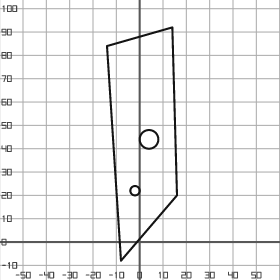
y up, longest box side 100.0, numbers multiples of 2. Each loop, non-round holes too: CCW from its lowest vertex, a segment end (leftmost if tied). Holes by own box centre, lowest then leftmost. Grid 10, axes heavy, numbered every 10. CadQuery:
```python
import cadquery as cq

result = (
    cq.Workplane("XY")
    .moveTo(-8.0, -8.0)
    .lineTo(16.0, 20.0)
    .lineTo(14.0, 92.0)
    .lineTo(-14.0, 84.0)
    .close()
    .moveTo(-2.0, 22.0)
    .circle(2.0)
    .moveTo(4.0, 44.0)
    .circle(4.0)
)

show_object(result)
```